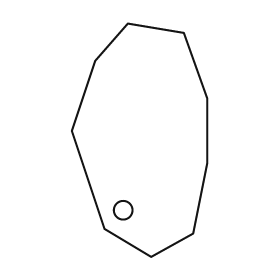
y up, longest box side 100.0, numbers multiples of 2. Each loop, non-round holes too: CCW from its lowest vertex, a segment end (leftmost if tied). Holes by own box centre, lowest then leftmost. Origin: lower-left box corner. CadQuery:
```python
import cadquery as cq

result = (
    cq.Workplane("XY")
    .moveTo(34.0, 0.0)
    .lineTo(52.0, 10.0)
    .lineTo(58.0, 40.0)
    .lineTo(58.0, 68.0)
    .lineTo(48.0, 96.0)
    .lineTo(24.0, 100.0)
    .lineTo(10.0, 84.0)
    .lineTo(0.0, 54.0)
    .lineTo(14.0, 12.0)
    .close()
    .moveTo(22.0, 20.0)
    .circle(4.0)
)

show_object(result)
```